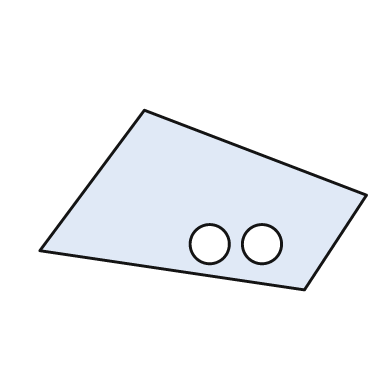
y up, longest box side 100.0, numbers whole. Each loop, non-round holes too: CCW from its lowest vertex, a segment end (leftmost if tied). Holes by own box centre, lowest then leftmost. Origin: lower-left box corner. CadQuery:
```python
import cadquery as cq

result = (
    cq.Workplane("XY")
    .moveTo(81.0, 0.0)
    .lineTo(100.0, 29.0)
    .lineTo(32.0, 55.0)
    .lineTo(0.0, 12.0)
    .close()
    .moveTo(52.0, 14.0)
    .circle(6.0)
    .moveTo(68.0, 14.0)
    .circle(6.0)
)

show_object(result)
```